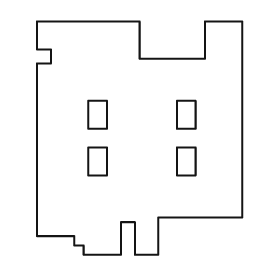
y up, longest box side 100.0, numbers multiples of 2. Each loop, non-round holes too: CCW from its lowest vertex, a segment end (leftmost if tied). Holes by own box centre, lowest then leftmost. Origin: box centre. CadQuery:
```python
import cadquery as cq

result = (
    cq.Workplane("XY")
    .moveTo(-24.0, -50.0)
    .lineTo(-8.0, -50.0)
    .lineTo(-8.0, -36.0)
    .lineTo(-2.0, -36.0)
    .lineTo(-2.0, -50.0)
    .lineTo(8.0, -50.0)
    .lineTo(8.0, -34.0)
    .lineTo(44.0, -34.0)
    .lineTo(44.0, 50.0)
    .lineTo(28.0, 50.0)
    .lineTo(28.0, 34.0)
    .lineTo(0.0, 34.0)
    .lineTo(0.0, 50.0)
    .lineTo(-44.0, 50.0)
    .lineTo(-44.0, 38.0)
    .lineTo(-38.0, 38.0)
    .lineTo(-38.0, 32.0)
    .lineTo(-44.0, 32.0)
    .lineTo(-44.0, -42.0)
    .lineTo(-28.0, -42.0)
    .lineTo(-28.0, -46.0)
    .lineTo(-24.0, -46.0)
    .close()
    .moveTo(-22.0, -16.0)
    .lineTo(-14.0, -16.0)
    .lineTo(-14.0, -4.0)
    .lineTo(-22.0, -4.0)
    .close()
    .moveTo(16.0, -16.0)
    .lineTo(24.0, -16.0)
    .lineTo(24.0, -4.0)
    .lineTo(16.0, -4.0)
    .close()
    .moveTo(-22.0, 4.0)
    .lineTo(-14.0, 4.0)
    .lineTo(-14.0, 16.0)
    .lineTo(-22.0, 16.0)
    .close()
    .moveTo(16.0, 4.0)
    .lineTo(24.0, 4.0)
    .lineTo(24.0, 16.0)
    .lineTo(16.0, 16.0)
    .close()
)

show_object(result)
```